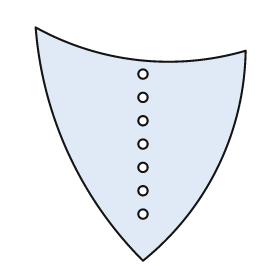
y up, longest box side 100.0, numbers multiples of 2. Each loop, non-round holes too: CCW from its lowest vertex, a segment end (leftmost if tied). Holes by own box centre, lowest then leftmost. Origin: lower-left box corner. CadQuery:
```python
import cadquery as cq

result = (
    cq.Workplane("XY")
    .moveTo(46.0, 0.0)
    .threePointArc((78.0, 40.0), (90.0, 90.0))
    .threePointArc((44.0, 86.0), (0.0, 100.0))
    .threePointArc((14.0, 46.0), (46.0, 0.0))
    .close()
    .moveTo(46.0, 20.0)
    .circle(2.0)
    .moveTo(46.0, 30.0)
    .circle(2.0)
    .moveTo(46.0, 40.0)
    .circle(2.0)
    .moveTo(46.0, 50.0)
    .circle(2.0)
    .moveTo(46.0, 60.0)
    .circle(2.0)
    .moveTo(46.0, 70.0)
    .circle(2.0)
    .moveTo(46.0, 80.0)
    .circle(2.0)
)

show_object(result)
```